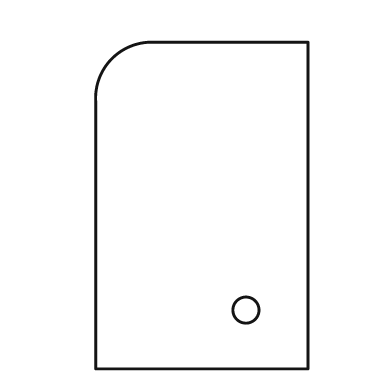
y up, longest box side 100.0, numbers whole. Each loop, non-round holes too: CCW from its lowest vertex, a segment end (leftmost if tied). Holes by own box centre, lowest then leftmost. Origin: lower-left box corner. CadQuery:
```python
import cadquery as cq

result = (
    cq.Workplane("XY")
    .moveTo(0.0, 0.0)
    .lineTo(65.0, 0.0)
    .lineTo(65.0, 100.0)
    .lineTo(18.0, 100.0)
    .threePointArc((5.0, 95.0), (0.0, 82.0))
    .close()
    .moveTo(46.0, 18.0)
    .circle(4.0)
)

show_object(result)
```